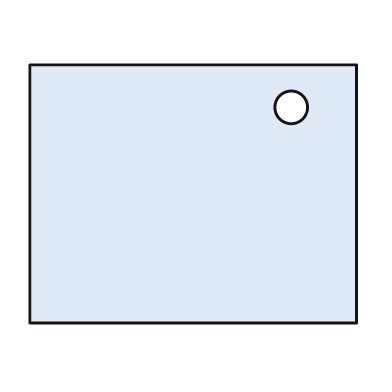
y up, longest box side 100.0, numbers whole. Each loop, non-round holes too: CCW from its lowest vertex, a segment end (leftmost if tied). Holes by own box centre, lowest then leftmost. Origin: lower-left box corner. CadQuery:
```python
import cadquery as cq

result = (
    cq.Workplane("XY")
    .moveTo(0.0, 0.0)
    .lineTo(100.0, 0.0)
    .lineTo(100.0, 79.0)
    .lineTo(0.0, 79.0)
    .close()
    .moveTo(80.0, 66.0)
    .circle(5.0)
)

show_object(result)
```